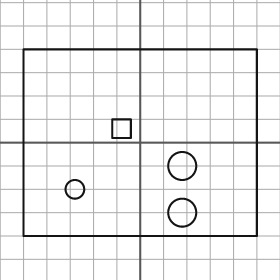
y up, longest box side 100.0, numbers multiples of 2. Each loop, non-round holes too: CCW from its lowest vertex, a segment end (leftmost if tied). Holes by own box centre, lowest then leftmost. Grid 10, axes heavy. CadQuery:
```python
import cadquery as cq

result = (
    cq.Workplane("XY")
    .moveTo(-50.0, -40.0)
    .lineTo(50.0, -40.0)
    .lineTo(50.0, 40.0)
    .lineTo(-50.0, 40.0)
    .close()
    .moveTo(18.0, -30.0)
    .circle(6.0)
    .moveTo(-28.0, -20.0)
    .circle(4.0)
    .moveTo(18.0, -10.0)
    .circle(6.0)
    .moveTo(-12.0, 2.0)
    .lineTo(-4.0, 2.0)
    .lineTo(-4.0, 10.0)
    .lineTo(-12.0, 10.0)
    .close()
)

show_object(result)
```